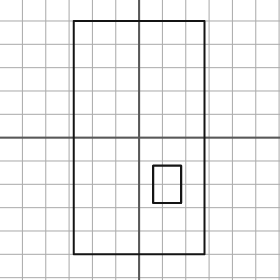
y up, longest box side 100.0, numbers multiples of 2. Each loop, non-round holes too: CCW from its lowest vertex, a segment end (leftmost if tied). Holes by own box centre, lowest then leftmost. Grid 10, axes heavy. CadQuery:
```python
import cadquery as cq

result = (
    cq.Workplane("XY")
    .moveTo(-28.0, -50.0)
    .lineTo(28.0, -50.0)
    .lineTo(28.0, 50.0)
    .lineTo(-28.0, 50.0)
    .close()
    .moveTo(6.0, -28.0)
    .lineTo(18.0, -28.0)
    .lineTo(18.0, -12.0)
    .lineTo(6.0, -12.0)
    .close()
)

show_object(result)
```